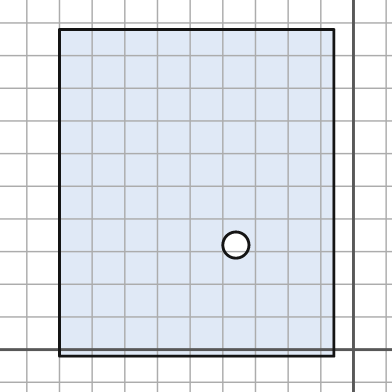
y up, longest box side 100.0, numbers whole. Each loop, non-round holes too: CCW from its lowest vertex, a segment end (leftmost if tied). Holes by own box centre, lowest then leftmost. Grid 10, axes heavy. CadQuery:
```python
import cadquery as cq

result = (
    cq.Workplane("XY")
    .moveTo(-90.0, -2.0)
    .lineTo(-6.0, -2.0)
    .lineTo(-6.0, 98.0)
    .lineTo(-90.0, 98.0)
    .close()
    .moveTo(-36.0, 32.0)
    .circle(4.0)
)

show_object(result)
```